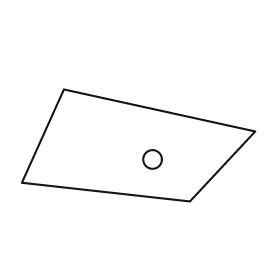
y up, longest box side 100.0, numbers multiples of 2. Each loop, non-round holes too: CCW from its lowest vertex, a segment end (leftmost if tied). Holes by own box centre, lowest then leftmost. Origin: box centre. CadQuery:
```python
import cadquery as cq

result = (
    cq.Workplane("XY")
    .moveTo(22.0, -24.0)
    .lineTo(50.0, 6.0)
    .lineTo(-32.0, 24.0)
    .lineTo(-50.0, -16.0)
    .close()
    .moveTo(6.0, -6.0)
    .circle(4.0)
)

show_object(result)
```